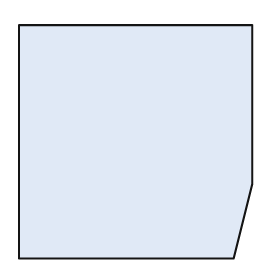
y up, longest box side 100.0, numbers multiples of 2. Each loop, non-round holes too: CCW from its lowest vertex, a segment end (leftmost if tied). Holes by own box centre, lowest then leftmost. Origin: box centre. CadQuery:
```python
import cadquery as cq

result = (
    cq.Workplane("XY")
    .moveTo(-50.0, -50.0)
    .lineTo(42.0, -50.0)
    .lineTo(50.0, -18.0)
    .lineTo(50.0, 50.0)
    .lineTo(-50.0, 50.0)
    .close()
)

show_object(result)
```